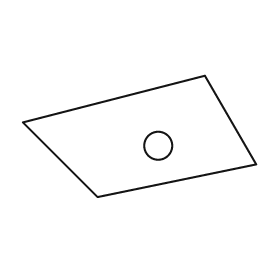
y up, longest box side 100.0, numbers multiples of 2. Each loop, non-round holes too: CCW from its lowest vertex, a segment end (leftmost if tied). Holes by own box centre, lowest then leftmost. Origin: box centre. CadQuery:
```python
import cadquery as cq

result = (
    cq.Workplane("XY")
    .moveTo(-18.0, -26.0)
    .lineTo(50.0, -12.0)
    .lineTo(28.0, 26.0)
    .lineTo(-50.0, 6.0)
    .close()
    .moveTo(8.0, -4.0)
    .circle(6.0)
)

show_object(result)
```